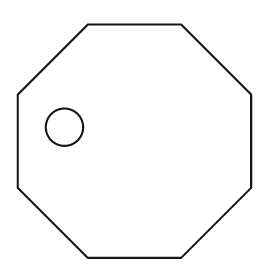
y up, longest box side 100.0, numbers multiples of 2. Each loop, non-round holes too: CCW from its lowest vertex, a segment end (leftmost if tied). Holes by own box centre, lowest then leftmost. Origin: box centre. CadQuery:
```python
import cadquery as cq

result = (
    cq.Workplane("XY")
    .moveTo(-20.0, -50.0)
    .lineTo(20.0, -50.0)
    .lineTo(50.0, -20.0)
    .lineTo(50.0, 20.0)
    .lineTo(20.0, 50.0)
    .lineTo(-20.0, 50.0)
    .lineTo(-50.0, 20.0)
    .lineTo(-50.0, -20.0)
    .close()
    .moveTo(-30.0, 6.0)
    .circle(8.0)
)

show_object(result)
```